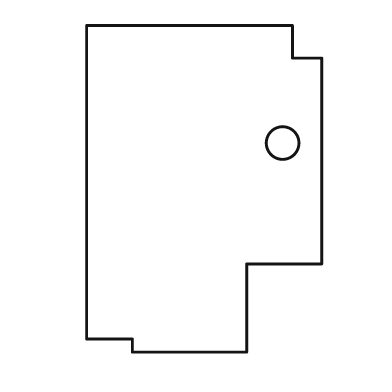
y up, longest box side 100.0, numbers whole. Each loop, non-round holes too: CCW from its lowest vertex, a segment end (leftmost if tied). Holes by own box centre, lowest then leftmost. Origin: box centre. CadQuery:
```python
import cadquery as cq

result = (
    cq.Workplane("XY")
    .moveTo(-22.0, -50.0)
    .lineTo(13.0, -50.0)
    .lineTo(13.0, -23.0)
    .lineTo(36.0, -23.0)
    .lineTo(36.0, 40.0)
    .lineTo(27.0, 40.0)
    .lineTo(27.0, 50.0)
    .lineTo(-36.0, 50.0)
    .lineTo(-36.0, -46.0)
    .lineTo(-22.0, -46.0)
    .close()
    .moveTo(24.0, 14.0)
    .circle(5.0)
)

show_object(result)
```